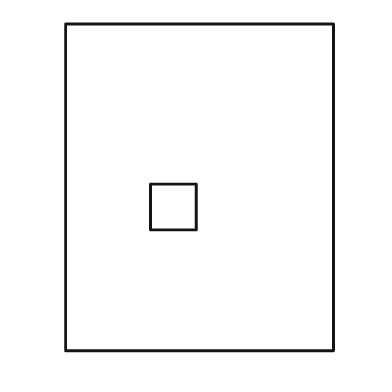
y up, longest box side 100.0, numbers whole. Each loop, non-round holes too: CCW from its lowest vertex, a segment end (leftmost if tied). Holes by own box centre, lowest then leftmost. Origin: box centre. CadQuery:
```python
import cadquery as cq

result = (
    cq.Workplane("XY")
    .moveTo(-41.0, -50.0)
    .lineTo(41.0, -50.0)
    .lineTo(41.0, 50.0)
    .lineTo(-41.0, 50.0)
    .close()
    .moveTo(-15.0, -13.0)
    .lineTo(-1.0, -13.0)
    .lineTo(-1.0, 1.0)
    .lineTo(-15.0, 1.0)
    .close()
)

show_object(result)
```